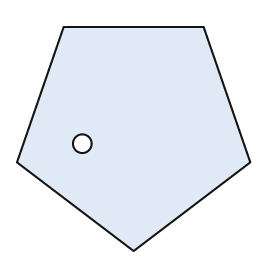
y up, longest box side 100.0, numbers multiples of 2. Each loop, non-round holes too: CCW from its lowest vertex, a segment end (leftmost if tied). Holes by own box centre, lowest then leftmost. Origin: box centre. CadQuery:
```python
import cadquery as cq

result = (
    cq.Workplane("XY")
    .moveTo(0.0, -48.0)
    .lineTo(50.0, -10.0)
    .lineTo(30.0, 48.0)
    .lineTo(-30.0, 48.0)
    .lineTo(-50.0, -10.0)
    .close()
    .moveTo(-22.0, -2.0)
    .circle(4.0)
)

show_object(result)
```